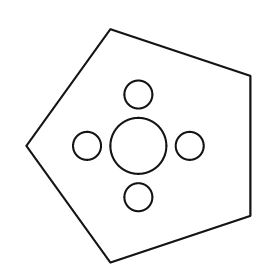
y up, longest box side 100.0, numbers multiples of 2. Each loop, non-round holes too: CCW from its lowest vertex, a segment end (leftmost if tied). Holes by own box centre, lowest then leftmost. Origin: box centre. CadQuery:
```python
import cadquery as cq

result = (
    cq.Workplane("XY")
    .moveTo(-12.0, -50.0)
    .lineTo(48.0, -30.0)
    .lineTo(48.0, 30.0)
    .lineTo(-12.0, 50.0)
    .lineTo(-48.0, 0.0)
    .close()
    .moveTo(0.0, -22.0)
    .circle(6.0)
    .moveTo(-22.0, 0.0)
    .circle(6.0)
    .moveTo(0.0, 0.0)
    .circle(12.0)
    .moveTo(22.0, 0.0)
    .circle(6.0)
    .moveTo(0.0, 22.0)
    .circle(6.0)
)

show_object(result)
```